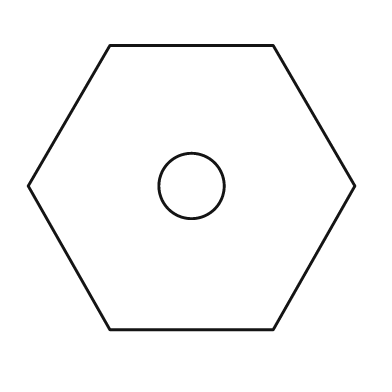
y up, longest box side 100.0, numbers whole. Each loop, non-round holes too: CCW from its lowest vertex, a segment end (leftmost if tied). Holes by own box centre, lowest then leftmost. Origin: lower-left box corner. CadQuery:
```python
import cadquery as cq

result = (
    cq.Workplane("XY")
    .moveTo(25.0, 0.0)
    .lineTo(75.0, 0.0)
    .lineTo(100.0, 44.0)
    .lineTo(75.0, 87.0)
    .lineTo(25.0, 87.0)
    .lineTo(0.0, 44.0)
    .close()
    .moveTo(50.0, 44.0)
    .circle(10.0)
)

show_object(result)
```